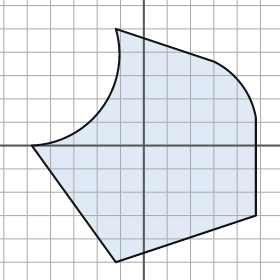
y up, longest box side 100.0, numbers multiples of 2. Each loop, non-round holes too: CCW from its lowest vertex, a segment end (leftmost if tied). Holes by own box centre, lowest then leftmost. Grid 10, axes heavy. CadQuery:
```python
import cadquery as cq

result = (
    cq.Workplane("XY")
    .moveTo(-12.0, -50.0)
    .lineTo(48.0, -30.0)
    .lineTo(48.0, 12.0)
    .threePointArc((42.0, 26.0), (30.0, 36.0))
    .lineTo(-12.0, 50.0)
    .threePointArc((-18.0, 16.0), (-48.0, 0.0))
    .close()
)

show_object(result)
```